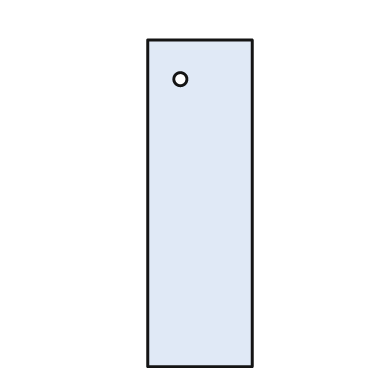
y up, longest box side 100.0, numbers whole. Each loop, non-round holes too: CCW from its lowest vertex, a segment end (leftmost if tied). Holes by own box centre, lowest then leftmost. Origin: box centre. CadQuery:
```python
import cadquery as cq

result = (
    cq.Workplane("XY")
    .moveTo(-16.0, -50.0)
    .lineTo(16.0, -50.0)
    .lineTo(16.0, 50.0)
    .lineTo(-16.0, 50.0)
    .close()
    .moveTo(-6.0, 38.0)
    .circle(2.0)
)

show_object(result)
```